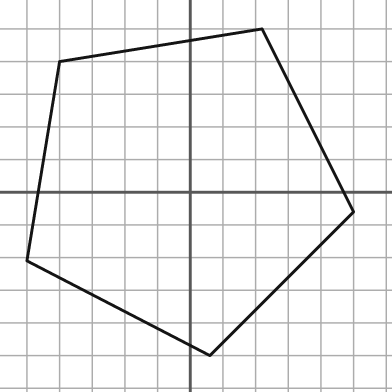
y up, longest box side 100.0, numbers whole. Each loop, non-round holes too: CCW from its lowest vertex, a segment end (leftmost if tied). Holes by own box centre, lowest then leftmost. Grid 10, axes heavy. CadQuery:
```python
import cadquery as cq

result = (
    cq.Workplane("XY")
    .moveTo(6.0, -50.0)
    .lineTo(50.0, -6.0)
    .lineTo(22.0, 50.0)
    .lineTo(-40.0, 40.0)
    .lineTo(-50.0, -21.0)
    .close()
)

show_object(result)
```